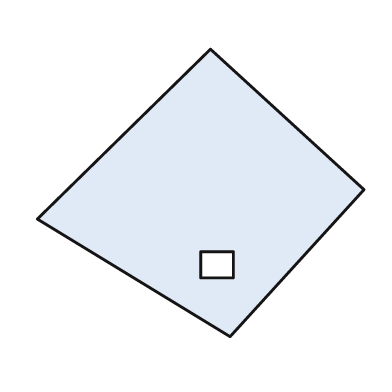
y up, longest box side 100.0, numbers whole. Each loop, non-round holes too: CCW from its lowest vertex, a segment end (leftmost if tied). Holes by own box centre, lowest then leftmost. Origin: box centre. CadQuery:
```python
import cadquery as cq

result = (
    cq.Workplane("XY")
    .moveTo(9.0, -44.0)
    .lineTo(50.0, 1.0)
    .lineTo(3.0, 44.0)
    .lineTo(-50.0, -8.0)
    .close()
    .moveTo(0.0, -26.0)
    .lineTo(10.0, -26.0)
    .lineTo(10.0, -18.0)
    .lineTo(0.0, -18.0)
    .close()
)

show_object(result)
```